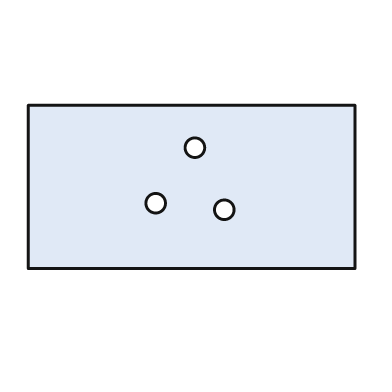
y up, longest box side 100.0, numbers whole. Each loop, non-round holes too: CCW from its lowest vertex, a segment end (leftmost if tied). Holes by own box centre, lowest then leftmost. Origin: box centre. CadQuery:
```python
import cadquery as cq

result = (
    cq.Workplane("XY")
    .moveTo(-50.0, -25.0)
    .lineTo(50.0, -25.0)
    .lineTo(50.0, 25.0)
    .lineTo(-50.0, 25.0)
    .close()
    .moveTo(10.0, -7.0)
    .circle(3.0)
    .moveTo(-11.0, -5.0)
    .circle(3.0)
    .moveTo(1.0, 12.0)
    .circle(3.0)
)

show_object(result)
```